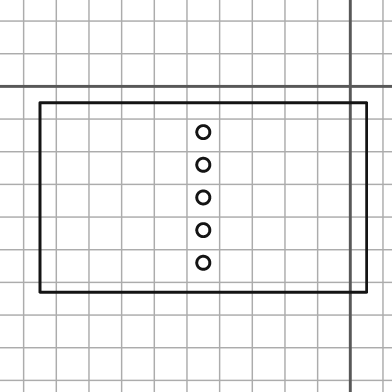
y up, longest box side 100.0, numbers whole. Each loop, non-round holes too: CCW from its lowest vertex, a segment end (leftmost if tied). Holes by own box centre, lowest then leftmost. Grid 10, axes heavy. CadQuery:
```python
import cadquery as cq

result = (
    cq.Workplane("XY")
    .moveTo(-95.0, -63.0)
    .lineTo(5.0, -63.0)
    .lineTo(5.0, -5.0)
    .lineTo(-95.0, -5.0)
    .close()
    .moveTo(-45.0, -54.0)
    .circle(2.0)
    .moveTo(-45.0, -44.0)
    .circle(2.0)
    .moveTo(-45.0, -34.0)
    .circle(2.0)
    .moveTo(-45.0, -24.0)
    .circle(2.0)
    .moveTo(-45.0, -14.0)
    .circle(2.0)
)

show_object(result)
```